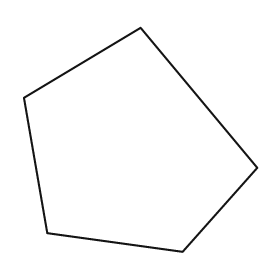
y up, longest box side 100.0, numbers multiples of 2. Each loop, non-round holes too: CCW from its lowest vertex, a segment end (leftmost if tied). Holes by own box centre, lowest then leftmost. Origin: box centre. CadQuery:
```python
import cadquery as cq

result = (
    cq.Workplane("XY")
    .moveTo(18.0, -48.0)
    .lineTo(50.0, -12.0)
    .lineTo(0.0, 48.0)
    .lineTo(-50.0, 18.0)
    .lineTo(-40.0, -40.0)
    .close()
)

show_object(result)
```